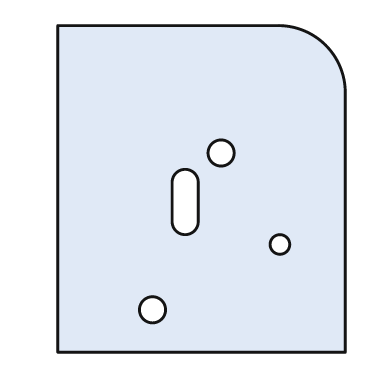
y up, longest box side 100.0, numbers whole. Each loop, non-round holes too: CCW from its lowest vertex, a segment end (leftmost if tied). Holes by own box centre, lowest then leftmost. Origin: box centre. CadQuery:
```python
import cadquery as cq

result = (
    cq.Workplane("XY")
    .moveTo(-44.0, -50.0)
    .lineTo(44.0, -50.0)
    .lineTo(44.0, 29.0)
    .threePointArc((38.0, 44.0), (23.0, 50.0))
    .lineTo(-44.0, 50.0)
    .close()
    .moveTo(-15.0, -37.0)
    .circle(4.0)
    .moveTo(24.0, -17.0)
    .circle(3.0)
    .moveTo(-9.0, -10.0)
    .threePointArc((-5.0, -14.0), (-1.0, -10.0))
    .lineTo(-1.0, 2.0)
    .threePointArc((-5.0, 6.0), (-9.0, 2.0))
    .close()
    .moveTo(6.0, 11.0)
    .circle(4.0)
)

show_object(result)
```